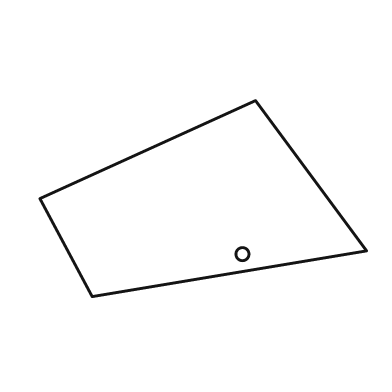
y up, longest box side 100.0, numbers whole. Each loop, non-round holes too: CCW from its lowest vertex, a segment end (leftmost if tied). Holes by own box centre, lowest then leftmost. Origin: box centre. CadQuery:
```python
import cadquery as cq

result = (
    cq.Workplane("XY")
    .moveTo(-34.0, -30.0)
    .lineTo(50.0, -16.0)
    .lineTo(16.0, 30.0)
    .lineTo(-50.0, 0.0)
    .close()
    .moveTo(12.0, -17.0)
    .circle(2.0)
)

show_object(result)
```